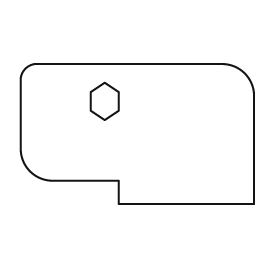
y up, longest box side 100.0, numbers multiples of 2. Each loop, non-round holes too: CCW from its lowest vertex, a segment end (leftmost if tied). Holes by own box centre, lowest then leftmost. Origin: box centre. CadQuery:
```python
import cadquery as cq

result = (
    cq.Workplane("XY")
    .moveTo(-8.0, -30.0)
    .lineTo(50.0, -30.0)
    .lineTo(50.0, 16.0)
    .threePointArc((46.0, 26.0), (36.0, 30.0))
    .lineTo(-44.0, 30.0)
    .threePointArc((-48.0, 28.0), (-50.0, 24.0))
    .lineTo(-50.0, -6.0)
    .threePointArc((-46.0, -16.0), (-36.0, -20.0))
    .lineTo(-8.0, -20.0)
    .close()
    .moveTo(-14.0, 6.0)
    .lineTo(-8.0, 10.0)
    .lineTo(-8.0, 18.0)
    .lineTo(-14.0, 22.0)
    .lineTo(-20.0, 18.0)
    .lineTo(-20.0, 10.0)
    .close()
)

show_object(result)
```